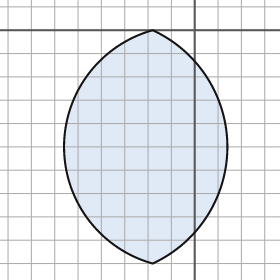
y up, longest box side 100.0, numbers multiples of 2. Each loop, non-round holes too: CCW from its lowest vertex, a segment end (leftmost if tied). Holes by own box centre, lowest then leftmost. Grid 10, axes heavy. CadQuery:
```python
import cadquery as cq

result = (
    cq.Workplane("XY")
    .moveTo(-18.0, -100.0)
    .threePointArc((14.0, -50.0), (-18.0, 0.0))
    .threePointArc((-56.0, -50.0), (-18.0, -100.0))
    .close()
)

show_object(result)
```